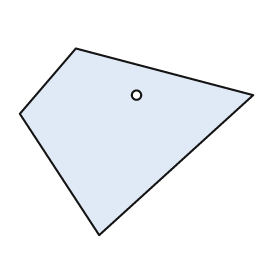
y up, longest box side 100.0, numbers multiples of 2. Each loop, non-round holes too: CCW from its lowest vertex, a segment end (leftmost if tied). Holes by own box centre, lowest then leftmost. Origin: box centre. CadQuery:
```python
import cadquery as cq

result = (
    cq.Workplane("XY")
    .moveTo(-16.0, -40.0)
    .lineTo(50.0, 20.0)
    .lineTo(-26.0, 40.0)
    .lineTo(-50.0, 12.0)
    .close()
    .moveTo(0.0, 20.0)
    .circle(2.0)
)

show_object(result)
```